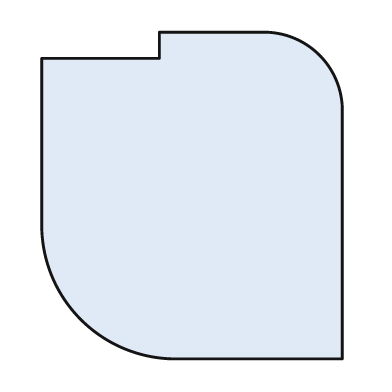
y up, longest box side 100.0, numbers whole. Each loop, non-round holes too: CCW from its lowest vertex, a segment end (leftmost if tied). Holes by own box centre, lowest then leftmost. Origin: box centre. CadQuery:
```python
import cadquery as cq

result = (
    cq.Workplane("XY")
    .moveTo(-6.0, -50.0)
    .lineTo(46.0, -50.0)
    .lineTo(46.0, 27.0)
    .threePointArc((39.0, 43.0), (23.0, 50.0))
    .lineTo(-10.0, 50.0)
    .lineTo(-10.0, 42.0)
    .lineTo(-46.0, 42.0)
    .lineTo(-46.0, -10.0)
    .threePointArc((-34.0, -38.0), (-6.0, -50.0))
    .close()
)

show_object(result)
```